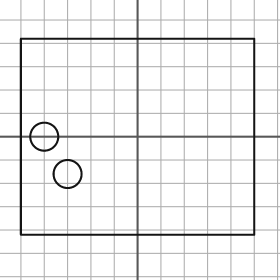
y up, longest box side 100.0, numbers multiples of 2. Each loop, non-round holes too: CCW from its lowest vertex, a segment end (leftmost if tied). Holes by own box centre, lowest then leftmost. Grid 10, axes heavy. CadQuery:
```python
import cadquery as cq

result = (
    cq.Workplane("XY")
    .moveTo(-50.0, -42.0)
    .lineTo(50.0, -42.0)
    .lineTo(50.0, 42.0)
    .lineTo(-50.0, 42.0)
    .close()
    .moveTo(-30.0, -16.0)
    .circle(6.0)
    .moveTo(-40.0, 0.0)
    .circle(6.0)
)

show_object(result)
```